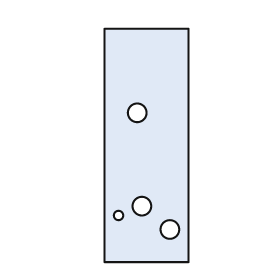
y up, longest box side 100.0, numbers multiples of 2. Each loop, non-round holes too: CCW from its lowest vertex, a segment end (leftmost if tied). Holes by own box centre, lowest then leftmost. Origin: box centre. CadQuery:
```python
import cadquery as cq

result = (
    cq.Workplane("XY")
    .moveTo(-18.0, -50.0)
    .lineTo(18.0, -50.0)
    .lineTo(18.0, 50.0)
    .lineTo(-18.0, 50.0)
    .close()
    .moveTo(10.0, -36.0)
    .circle(4.0)
    .moveTo(-12.0, -30.0)
    .circle(2.0)
    .moveTo(-2.0, -26.0)
    .circle(4.0)
    .moveTo(-4.0, 14.0)
    .circle(4.0)
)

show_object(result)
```